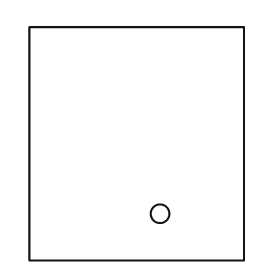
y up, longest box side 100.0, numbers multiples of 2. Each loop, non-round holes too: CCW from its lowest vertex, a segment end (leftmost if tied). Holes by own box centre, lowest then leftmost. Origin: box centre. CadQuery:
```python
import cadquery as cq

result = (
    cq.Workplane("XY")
    .moveTo(-46.0, -50.0)
    .lineTo(46.0, -50.0)
    .lineTo(46.0, 50.0)
    .lineTo(-46.0, 50.0)
    .close()
    .moveTo(10.0, -30.0)
    .circle(4.0)
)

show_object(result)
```